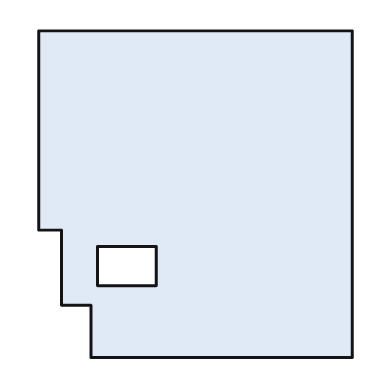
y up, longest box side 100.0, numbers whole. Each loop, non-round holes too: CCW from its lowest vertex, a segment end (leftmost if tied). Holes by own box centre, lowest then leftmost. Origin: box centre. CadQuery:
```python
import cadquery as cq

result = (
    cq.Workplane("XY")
    .moveTo(-32.0, -50.0)
    .lineTo(48.0, -50.0)
    .lineTo(48.0, 50.0)
    .lineTo(-48.0, 50.0)
    .lineTo(-48.0, -11.0)
    .lineTo(-41.0, -11.0)
    .lineTo(-41.0, -34.0)
    .lineTo(-32.0, -34.0)
    .close()
    .moveTo(-30.0, -28.0)
    .lineTo(-12.0, -28.0)
    .lineTo(-12.0, -16.0)
    .lineTo(-30.0, -16.0)
    .close()
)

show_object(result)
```